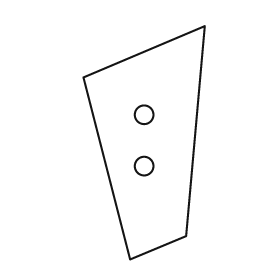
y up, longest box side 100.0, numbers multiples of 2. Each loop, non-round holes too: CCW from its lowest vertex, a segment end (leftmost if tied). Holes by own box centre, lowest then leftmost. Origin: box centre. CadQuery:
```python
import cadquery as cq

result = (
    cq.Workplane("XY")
    .moveTo(-6.0, -50.0)
    .lineTo(18.0, -40.0)
    .lineTo(26.0, 50.0)
    .lineTo(-26.0, 28.0)
    .close()
    .moveTo(0.0, -10.0)
    .circle(4.0)
    .moveTo(0.0, 12.0)
    .circle(4.0)
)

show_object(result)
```